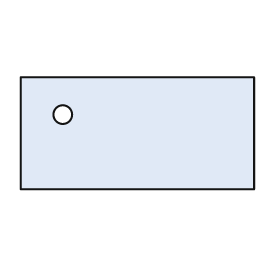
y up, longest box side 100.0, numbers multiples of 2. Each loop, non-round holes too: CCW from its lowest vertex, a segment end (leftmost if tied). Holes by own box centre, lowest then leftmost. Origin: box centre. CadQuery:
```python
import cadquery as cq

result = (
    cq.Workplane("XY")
    .moveTo(-50.0, -24.0)
    .lineTo(50.0, -24.0)
    .lineTo(50.0, 24.0)
    .lineTo(-50.0, 24.0)
    .close()
    .moveTo(-32.0, 8.0)
    .circle(4.0)
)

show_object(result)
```